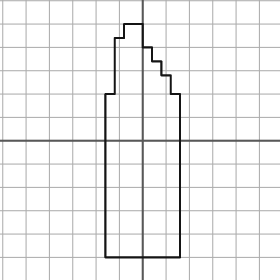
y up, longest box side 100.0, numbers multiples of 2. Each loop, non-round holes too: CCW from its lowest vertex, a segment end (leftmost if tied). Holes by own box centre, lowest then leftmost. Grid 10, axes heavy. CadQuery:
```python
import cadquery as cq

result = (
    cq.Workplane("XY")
    .moveTo(-16.0, -50.0)
    .lineTo(16.0, -50.0)
    .lineTo(16.0, 20.0)
    .lineTo(12.0, 20.0)
    .lineTo(12.0, 28.0)
    .lineTo(8.0, 28.0)
    .lineTo(8.0, 34.0)
    .lineTo(4.0, 34.0)
    .lineTo(4.0, 40.0)
    .lineTo(0.0, 40.0)
    .lineTo(0.0, 50.0)
    .lineTo(-8.0, 50.0)
    .lineTo(-8.0, 44.0)
    .lineTo(-12.0, 44.0)
    .lineTo(-12.0, 20.0)
    .lineTo(-16.0, 20.0)
    .close()
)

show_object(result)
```